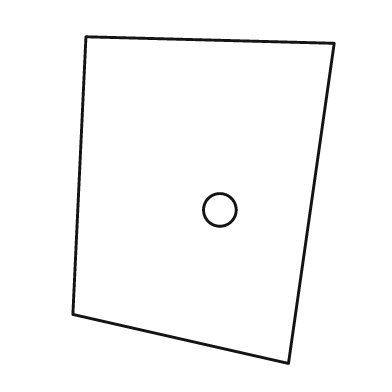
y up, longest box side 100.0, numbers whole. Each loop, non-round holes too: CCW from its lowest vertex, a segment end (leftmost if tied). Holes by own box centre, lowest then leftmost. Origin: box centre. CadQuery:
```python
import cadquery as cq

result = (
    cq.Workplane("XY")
    .moveTo(26.0, -50.0)
    .lineTo(40.0, 48.0)
    .lineTo(-36.0, 50.0)
    .lineTo(-40.0, -35.0)
    .close()
    .moveTo(5.0, -3.0)
    .circle(5.0)
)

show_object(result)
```